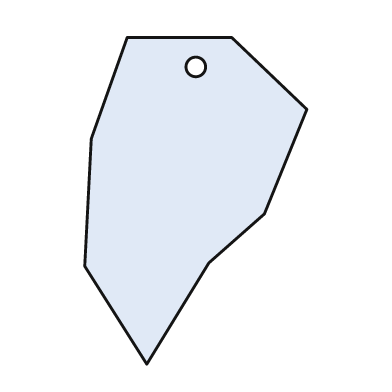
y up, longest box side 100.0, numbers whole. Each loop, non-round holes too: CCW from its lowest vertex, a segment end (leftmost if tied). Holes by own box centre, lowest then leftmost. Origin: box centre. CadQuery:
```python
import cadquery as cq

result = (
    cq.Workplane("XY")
    .moveTo(-15.0, -50.0)
    .lineTo(4.0, -19.0)
    .lineTo(21.0, -4.0)
    .lineTo(34.0, 28.0)
    .lineTo(11.0, 50.0)
    .lineTo(-21.0, 50.0)
    .lineTo(-32.0, 19.0)
    .lineTo(-34.0, -20.0)
    .close()
    .moveTo(0.0, 41.0)
    .circle(3.0)
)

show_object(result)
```